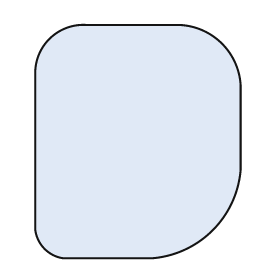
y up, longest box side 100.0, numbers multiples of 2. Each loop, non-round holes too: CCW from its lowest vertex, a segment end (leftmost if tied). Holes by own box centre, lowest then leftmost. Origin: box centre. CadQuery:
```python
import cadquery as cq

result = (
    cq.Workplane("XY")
    .moveTo(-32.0, -50.0)
    .lineTo(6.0, -50.0)
    .threePointArc((32.0, -38.0), (44.0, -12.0))
    .lineTo(44.0, 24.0)
    .threePointArc((36.0, 42.0), (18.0, 50.0))
    .lineTo(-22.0, 50.0)
    .threePointArc((-38.0, 44.0), (-44.0, 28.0))
    .lineTo(-44.0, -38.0)
    .threePointArc((-40.0, -46.0), (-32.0, -50.0))
    .close()
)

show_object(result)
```